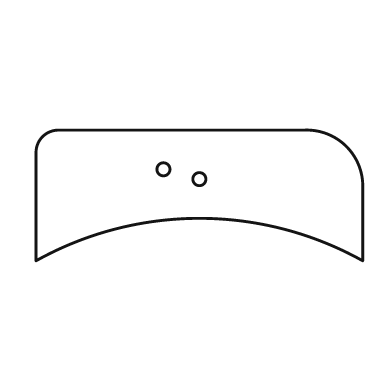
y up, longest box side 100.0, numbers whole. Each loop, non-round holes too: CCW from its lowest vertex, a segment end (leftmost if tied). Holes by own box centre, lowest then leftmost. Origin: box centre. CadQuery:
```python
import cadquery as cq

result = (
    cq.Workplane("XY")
    .moveTo(-50.0, -20.0)
    .threePointArc((0.0, -7.0), (50.0, -20.0))
    .lineTo(50.0, 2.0)
    .threePointArc((45.0, 15.0), (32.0, 20.0))
    .lineTo(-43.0, 20.0)
    .threePointArc((-48.0, 18.0), (-50.0, 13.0))
    .close()
    .moveTo(0.0, 5.0)
    .circle(2.0)
    .moveTo(-11.0, 8.0)
    .circle(2.0)
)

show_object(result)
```